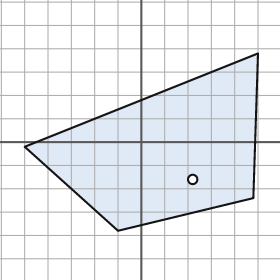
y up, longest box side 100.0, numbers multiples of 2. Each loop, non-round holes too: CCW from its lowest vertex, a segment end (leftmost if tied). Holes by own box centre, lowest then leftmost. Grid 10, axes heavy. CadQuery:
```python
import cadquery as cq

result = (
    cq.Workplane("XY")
    .moveTo(-10.0, -38.0)
    .lineTo(48.0, -24.0)
    .lineTo(50.0, 38.0)
    .lineTo(-50.0, -2.0)
    .close()
    .moveTo(22.0, -16.0)
    .circle(2.0)
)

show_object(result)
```